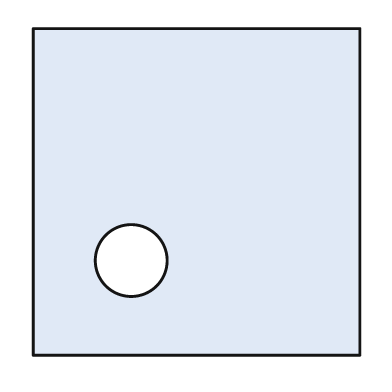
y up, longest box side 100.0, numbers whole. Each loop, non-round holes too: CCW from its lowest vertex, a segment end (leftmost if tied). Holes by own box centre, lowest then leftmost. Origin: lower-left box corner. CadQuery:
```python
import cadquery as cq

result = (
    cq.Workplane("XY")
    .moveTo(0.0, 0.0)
    .lineTo(100.0, 0.0)
    .lineTo(100.0, 100.0)
    .lineTo(0.0, 100.0)
    .close()
    .moveTo(30.0, 29.0)
    .circle(11.0)
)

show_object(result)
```